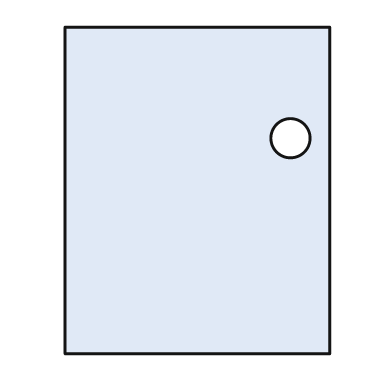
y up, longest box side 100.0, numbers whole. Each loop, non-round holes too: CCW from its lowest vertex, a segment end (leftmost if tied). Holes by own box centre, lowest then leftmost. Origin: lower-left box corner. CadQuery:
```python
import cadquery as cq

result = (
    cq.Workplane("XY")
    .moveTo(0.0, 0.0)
    .lineTo(81.0, 0.0)
    .lineTo(81.0, 100.0)
    .lineTo(0.0, 100.0)
    .close()
    .moveTo(69.0, 66.0)
    .circle(6.0)
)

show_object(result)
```